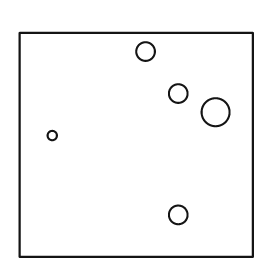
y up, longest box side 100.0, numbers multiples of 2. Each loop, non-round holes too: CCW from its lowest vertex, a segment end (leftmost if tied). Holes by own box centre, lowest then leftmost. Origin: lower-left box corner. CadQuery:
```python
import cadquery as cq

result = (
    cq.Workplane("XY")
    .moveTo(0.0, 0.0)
    .lineTo(100.0, 0.0)
    .lineTo(100.0, 96.0)
    .lineTo(0.0, 96.0)
    .close()
    .moveTo(68.0, 18.0)
    .circle(4.0)
    .moveTo(14.0, 52.0)
    .circle(2.0)
    .moveTo(84.0, 62.0)
    .circle(6.0)
    .moveTo(68.0, 70.0)
    .circle(4.0)
    .moveTo(54.0, 88.0)
    .circle(4.0)
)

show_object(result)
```